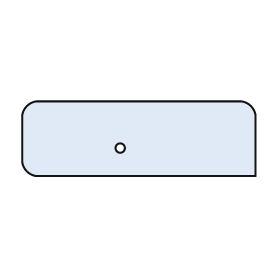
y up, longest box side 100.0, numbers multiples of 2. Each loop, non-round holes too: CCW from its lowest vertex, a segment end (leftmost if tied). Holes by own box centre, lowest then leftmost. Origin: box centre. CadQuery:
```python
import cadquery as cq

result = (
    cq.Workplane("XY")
    .moveTo(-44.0, -16.0)
    .lineTo(50.0, -16.0)
    .lineTo(50.0, 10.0)
    .threePointArc((48.0, 14.0), (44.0, 16.0))
    .lineTo(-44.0, 16.0)
    .threePointArc((-48.0, 14.0), (-50.0, 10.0))
    .lineTo(-50.0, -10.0)
    .threePointArc((-48.0, -14.0), (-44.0, -16.0))
    .close()
    .moveTo(-8.0, -4.0)
    .circle(2.0)
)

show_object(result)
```